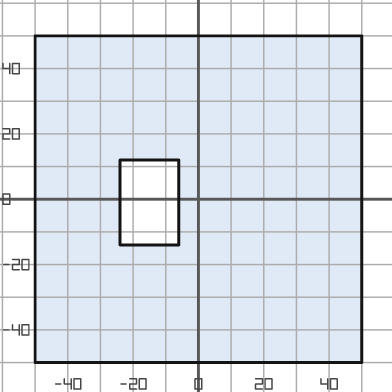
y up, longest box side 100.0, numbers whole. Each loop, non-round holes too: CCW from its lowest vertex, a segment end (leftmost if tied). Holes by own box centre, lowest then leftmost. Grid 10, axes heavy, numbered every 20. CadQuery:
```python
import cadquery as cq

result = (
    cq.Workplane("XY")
    .moveTo(-50.0, -50.0)
    .lineTo(50.0, -50.0)
    .lineTo(50.0, 50.0)
    .lineTo(-50.0, 50.0)
    .close()
    .moveTo(-24.0, -14.0)
    .lineTo(-6.0, -14.0)
    .lineTo(-6.0, 12.0)
    .lineTo(-24.0, 12.0)
    .close()
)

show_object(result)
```